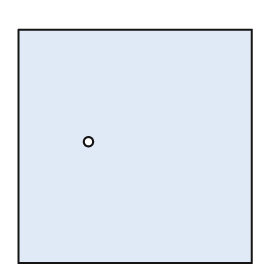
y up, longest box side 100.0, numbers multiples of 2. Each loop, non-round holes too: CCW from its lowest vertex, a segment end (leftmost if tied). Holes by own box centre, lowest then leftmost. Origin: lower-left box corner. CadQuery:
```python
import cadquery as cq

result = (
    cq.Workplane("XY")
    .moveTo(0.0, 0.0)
    .lineTo(100.0, 0.0)
    .lineTo(100.0, 100.0)
    .lineTo(0.0, 100.0)
    .close()
    .moveTo(30.0, 52.0)
    .circle(2.0)
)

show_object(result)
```